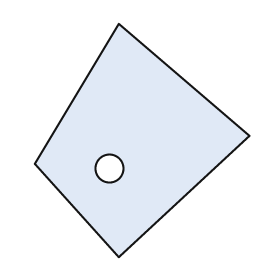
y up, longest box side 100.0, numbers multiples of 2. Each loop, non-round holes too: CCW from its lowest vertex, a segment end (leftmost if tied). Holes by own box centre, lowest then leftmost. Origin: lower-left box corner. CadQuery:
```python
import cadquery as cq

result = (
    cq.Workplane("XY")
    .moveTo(36.0, 0.0)
    .lineTo(92.0, 52.0)
    .lineTo(36.0, 100.0)
    .lineTo(0.0, 40.0)
    .close()
    .moveTo(32.0, 38.0)
    .circle(6.0)
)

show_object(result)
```